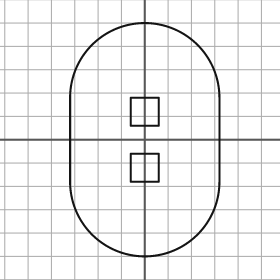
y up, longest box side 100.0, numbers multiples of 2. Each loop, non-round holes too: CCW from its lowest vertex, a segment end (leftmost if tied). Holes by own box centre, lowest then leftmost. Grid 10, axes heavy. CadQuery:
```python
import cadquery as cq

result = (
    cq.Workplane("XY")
    .moveTo(-32.0, -18.0)
    .threePointArc((0.0, -50.0), (32.0, -18.0))
    .lineTo(32.0, 18.0)
    .threePointArc((0.0, 50.0), (-32.0, 18.0))
    .close()
    .moveTo(-6.0, -18.0)
    .lineTo(6.0, -18.0)
    .lineTo(6.0, -6.0)
    .lineTo(-6.0, -6.0)
    .close()
    .moveTo(-6.0, 6.0)
    .lineTo(6.0, 6.0)
    .lineTo(6.0, 18.0)
    .lineTo(-6.0, 18.0)
    .close()
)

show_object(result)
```